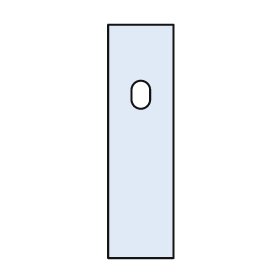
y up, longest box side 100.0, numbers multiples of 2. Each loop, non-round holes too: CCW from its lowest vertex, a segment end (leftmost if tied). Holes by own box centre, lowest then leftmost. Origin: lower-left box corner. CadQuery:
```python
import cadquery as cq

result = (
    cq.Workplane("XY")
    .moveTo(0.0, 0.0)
    .lineTo(28.0, 0.0)
    .lineTo(28.0, 100.0)
    .lineTo(0.0, 100.0)
    .close()
    .moveTo(10.0, 68.0)
    .threePointArc((14.0, 64.0), (18.0, 68.0))
    .lineTo(18.0, 72.0)
    .threePointArc((14.0, 76.0), (10.0, 72.0))
    .close()
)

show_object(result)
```